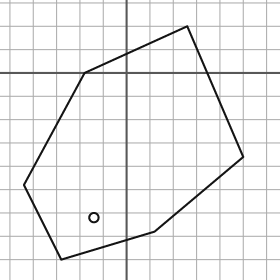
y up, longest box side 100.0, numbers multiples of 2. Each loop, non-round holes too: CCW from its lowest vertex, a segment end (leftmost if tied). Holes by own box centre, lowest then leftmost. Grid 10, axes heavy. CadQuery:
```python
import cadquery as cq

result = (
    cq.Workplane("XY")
    .moveTo(-28.0, -80.0)
    .lineTo(12.0, -68.0)
    .lineTo(50.0, -36.0)
    .lineTo(26.0, 20.0)
    .lineTo(-18.0, 0.0)
    .lineTo(-44.0, -48.0)
    .close()
    .moveTo(-14.0, -62.0)
    .circle(2.0)
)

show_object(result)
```